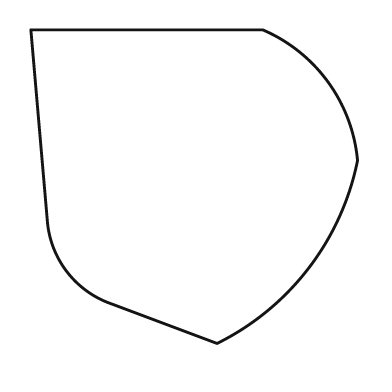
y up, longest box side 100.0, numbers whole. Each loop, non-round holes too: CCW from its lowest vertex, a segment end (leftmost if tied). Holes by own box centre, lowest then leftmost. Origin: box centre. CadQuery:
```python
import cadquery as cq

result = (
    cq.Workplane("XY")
    .moveTo(7.0, -48.0)
    .threePointArc((35.0, -25.0), (50.0, 8.0))
    .threePointArc((41.0, 32.0), (21.0, 48.0))
    .lineTo(-50.0, 48.0)
    .lineTo(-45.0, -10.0)
    .threePointArc((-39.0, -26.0), (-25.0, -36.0))
    .close()
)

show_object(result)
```